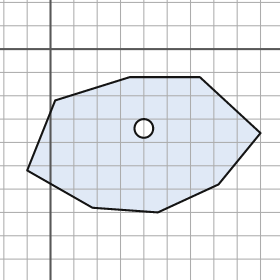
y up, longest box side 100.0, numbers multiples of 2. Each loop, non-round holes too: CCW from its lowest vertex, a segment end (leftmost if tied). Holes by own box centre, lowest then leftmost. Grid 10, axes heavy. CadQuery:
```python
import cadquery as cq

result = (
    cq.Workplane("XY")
    .moveTo(46.0, -70.0)
    .lineTo(72.0, -58.0)
    .lineTo(90.0, -36.0)
    .lineTo(64.0, -12.0)
    .lineTo(34.0, -12.0)
    .lineTo(2.0, -22.0)
    .lineTo(-10.0, -52.0)
    .lineTo(18.0, -68.0)
    .close()
    .moveTo(40.0, -34.0)
    .circle(4.0)
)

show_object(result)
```